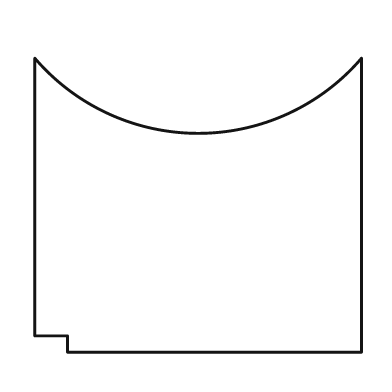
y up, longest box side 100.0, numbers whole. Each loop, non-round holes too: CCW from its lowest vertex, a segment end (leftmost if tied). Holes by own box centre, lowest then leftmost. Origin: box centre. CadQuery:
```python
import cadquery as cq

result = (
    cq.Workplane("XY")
    .moveTo(-40.0, -45.0)
    .lineTo(50.0, -45.0)
    .lineTo(50.0, 45.0)
    .threePointArc((0.0, 22.0), (-50.0, 45.0))
    .lineTo(-50.0, -40.0)
    .lineTo(-40.0, -40.0)
    .close()
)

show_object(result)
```